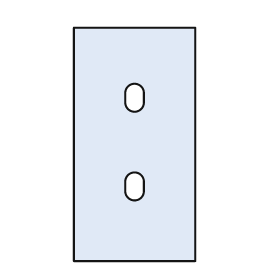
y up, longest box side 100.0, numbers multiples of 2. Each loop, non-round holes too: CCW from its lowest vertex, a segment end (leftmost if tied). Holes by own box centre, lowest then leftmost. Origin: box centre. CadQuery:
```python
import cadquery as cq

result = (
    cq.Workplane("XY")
    .moveTo(-26.0, -50.0)
    .lineTo(26.0, -50.0)
    .lineTo(26.0, 50.0)
    .lineTo(-26.0, 50.0)
    .close()
    .moveTo(-4.0, -20.0)
    .threePointArc((0.0, -24.0), (4.0, -20.0))
    .lineTo(4.0, -16.0)
    .threePointArc((0.0, -12.0), (-4.0, -16.0))
    .close()
    .moveTo(-4.0, 18.0)
    .threePointArc((0.0, 14.0), (4.0, 18.0))
    .lineTo(4.0, 22.0)
    .threePointArc((0.0, 26.0), (-4.0, 22.0))
    .close()
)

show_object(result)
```